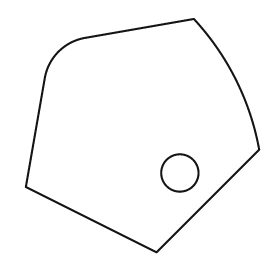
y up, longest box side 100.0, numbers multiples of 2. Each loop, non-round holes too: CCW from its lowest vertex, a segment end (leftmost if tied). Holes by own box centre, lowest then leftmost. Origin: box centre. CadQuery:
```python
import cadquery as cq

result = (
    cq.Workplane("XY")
    .moveTo(6.0, -50.0)
    .lineTo(50.0, -6.0)
    .threePointArc((40.0, 24.0), (22.0, 50.0))
    .lineTo(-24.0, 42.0)
    .threePointArc((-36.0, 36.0), (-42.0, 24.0))
    .lineTo(-50.0, -22.0)
    .close()
    .moveTo(16.0, -16.0)
    .circle(8.0)
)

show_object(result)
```